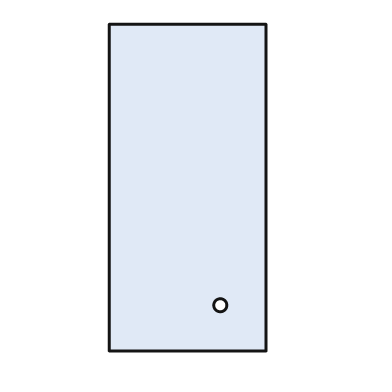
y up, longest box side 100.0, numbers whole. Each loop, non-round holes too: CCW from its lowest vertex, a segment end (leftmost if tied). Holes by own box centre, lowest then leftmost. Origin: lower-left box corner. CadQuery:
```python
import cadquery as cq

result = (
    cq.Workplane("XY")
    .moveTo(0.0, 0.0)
    .lineTo(48.0, 0.0)
    .lineTo(48.0, 100.0)
    .lineTo(0.0, 100.0)
    .close()
    .moveTo(34.0, 14.0)
    .circle(2.0)
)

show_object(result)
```